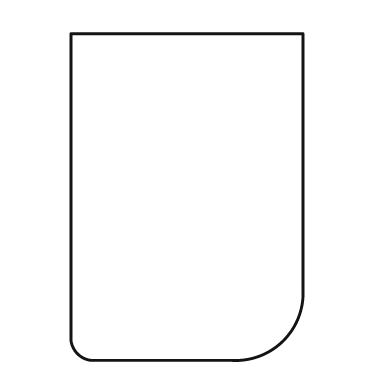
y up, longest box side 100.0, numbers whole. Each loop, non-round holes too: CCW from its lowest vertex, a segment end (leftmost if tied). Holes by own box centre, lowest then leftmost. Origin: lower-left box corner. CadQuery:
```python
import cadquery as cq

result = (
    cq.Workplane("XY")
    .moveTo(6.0, 0.0)
    .lineTo(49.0, 0.0)
    .threePointArc((65.0, 6.0), (71.0, 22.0))
    .lineTo(71.0, 100.0)
    .lineTo(0.0, 100.0)
    .lineTo(0.0, 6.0)
    .threePointArc((2.0, 2.0), (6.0, 0.0))
    .close()
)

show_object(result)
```